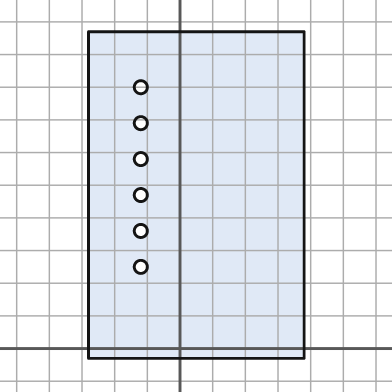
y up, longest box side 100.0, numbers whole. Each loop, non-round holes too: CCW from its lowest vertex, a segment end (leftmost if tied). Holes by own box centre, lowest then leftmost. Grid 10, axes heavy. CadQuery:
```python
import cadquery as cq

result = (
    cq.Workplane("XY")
    .moveTo(-28.0, -3.0)
    .lineTo(38.0, -3.0)
    .lineTo(38.0, 97.0)
    .lineTo(-28.0, 97.0)
    .close()
    .moveTo(-12.0, 25.0)
    .circle(2.0)
    .moveTo(-12.0, 36.0)
    .circle(2.0)
    .moveTo(-12.0, 47.0)
    .circle(2.0)
    .moveTo(-12.0, 58.0)
    .circle(2.0)
    .moveTo(-12.0, 69.0)
    .circle(2.0)
    .moveTo(-12.0, 80.0)
    .circle(2.0)
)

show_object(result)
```